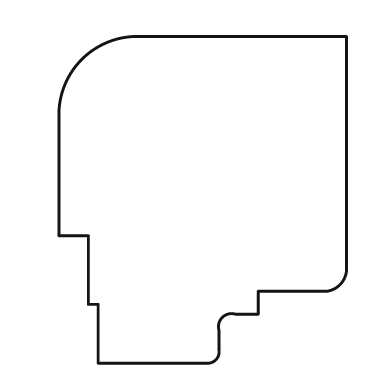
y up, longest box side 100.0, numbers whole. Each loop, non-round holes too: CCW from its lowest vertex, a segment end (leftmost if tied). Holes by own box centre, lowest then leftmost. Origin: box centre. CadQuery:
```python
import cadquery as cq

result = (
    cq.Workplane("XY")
    .moveTo(-32.0, -50.0)
    .lineTo(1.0, -50.0)
    .threePointArc((4.0, -49.0), (5.0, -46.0))
    .lineTo(5.0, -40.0)
    .threePointArc((6.0, -36.0), (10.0, -35.0))
    .lineTo(17.0, -35.0)
    .lineTo(17.0, -28.0)
    .lineTo(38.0, -28.0)
    .threePointArc((42.0, -26.0), (44.0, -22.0))
    .lineTo(44.0, 50.0)
    .lineTo(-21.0, 50.0)
    .threePointArc((-37.0, 43.0), (-44.0, 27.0))
    .lineTo(-44.0, -11.0)
    .lineTo(-35.0, -11.0)
    .lineTo(-35.0, -32.0)
    .lineTo(-32.0, -32.0)
    .close()
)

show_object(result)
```